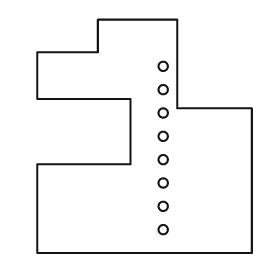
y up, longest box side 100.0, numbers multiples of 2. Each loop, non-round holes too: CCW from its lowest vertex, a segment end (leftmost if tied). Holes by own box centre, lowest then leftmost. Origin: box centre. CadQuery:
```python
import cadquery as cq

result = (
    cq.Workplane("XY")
    .moveTo(-46.0, -50.0)
    .lineTo(46.0, -50.0)
    .lineTo(46.0, 12.0)
    .lineTo(14.0, 12.0)
    .lineTo(14.0, 50.0)
    .lineTo(-20.0, 50.0)
    .lineTo(-20.0, 36.0)
    .lineTo(-46.0, 36.0)
    .lineTo(-46.0, 16.0)
    .lineTo(-6.0, 16.0)
    .lineTo(-6.0, -12.0)
    .lineTo(-46.0, -12.0)
    .close()
    .moveTo(8.0, -40.0)
    .circle(2.0)
    .moveTo(8.0, -30.0)
    .circle(2.0)
    .moveTo(8.0, -20.0)
    .circle(2.0)
    .moveTo(8.0, -10.0)
    .circle(2.0)
    .moveTo(8.0, 0.0)
    .circle(2.0)
    .moveTo(8.0, 10.0)
    .circle(2.0)
    .moveTo(8.0, 20.0)
    .circle(2.0)
    .moveTo(8.0, 30.0)
    .circle(2.0)
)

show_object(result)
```